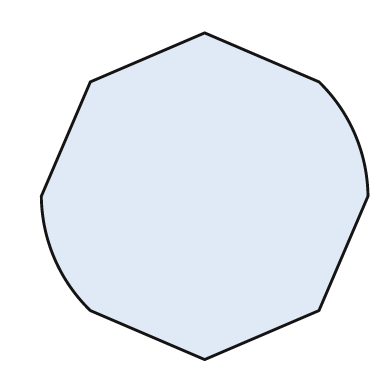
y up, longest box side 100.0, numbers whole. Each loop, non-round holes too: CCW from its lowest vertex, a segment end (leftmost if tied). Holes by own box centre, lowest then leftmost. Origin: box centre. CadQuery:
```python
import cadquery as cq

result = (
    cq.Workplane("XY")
    .moveTo(0.0, -50.0)
    .lineTo(35.0, -35.0)
    .lineTo(50.0, 0.0)
    .threePointArc((46.0, 19.0), (35.0, 35.0))
    .lineTo(0.0, 50.0)
    .lineTo(-35.0, 35.0)
    .lineTo(-50.0, 0.0)
    .threePointArc((-46.0, -19.0), (-35.0, -35.0))
    .close()
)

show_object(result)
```